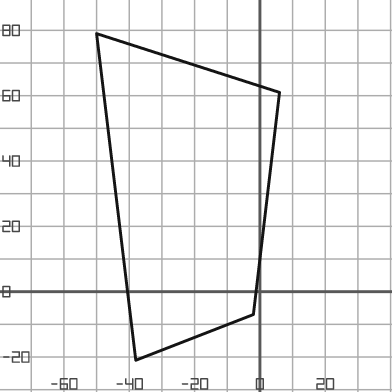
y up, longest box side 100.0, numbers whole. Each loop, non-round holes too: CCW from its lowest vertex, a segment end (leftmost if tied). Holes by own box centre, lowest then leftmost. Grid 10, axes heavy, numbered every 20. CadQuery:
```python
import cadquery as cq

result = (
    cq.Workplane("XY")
    .moveTo(-38.0, -21.0)
    .lineTo(-2.0, -7.0)
    .lineTo(6.0, 61.0)
    .lineTo(-50.0, 79.0)
    .close()
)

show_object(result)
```